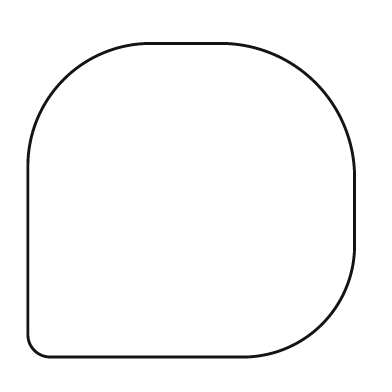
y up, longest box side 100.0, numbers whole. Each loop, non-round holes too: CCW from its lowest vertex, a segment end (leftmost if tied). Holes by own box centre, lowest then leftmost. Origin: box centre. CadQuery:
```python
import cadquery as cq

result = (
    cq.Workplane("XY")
    .moveTo(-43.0, -48.0)
    .lineTo(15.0, -48.0)
    .threePointArc((40.0, -38.0), (50.0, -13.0))
    .lineTo(50.0, 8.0)
    .threePointArc((38.0, 36.0), (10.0, 48.0))
    .lineTo(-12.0, 48.0)
    .threePointArc((-39.0, 37.0), (-50.0, 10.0))
    .lineTo(-50.0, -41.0)
    .threePointArc((-48.0, -46.0), (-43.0, -48.0))
    .close()
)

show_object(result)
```